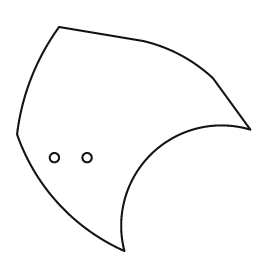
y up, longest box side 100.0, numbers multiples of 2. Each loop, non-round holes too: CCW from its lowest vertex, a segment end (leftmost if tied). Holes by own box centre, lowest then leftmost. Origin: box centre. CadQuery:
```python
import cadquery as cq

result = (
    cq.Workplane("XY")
    .moveTo(-4.0, -48.0)
    .threePointArc((8.0, -6.0), (50.0, 4.0))
    .lineTo(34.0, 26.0)
    .threePointArc((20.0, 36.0), (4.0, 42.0))
    .lineTo(-32.0, 48.0)
    .threePointArc((-44.0, 26.0), (-50.0, 2.0))
    .threePointArc((-32.0, -28.0), (-4.0, -48.0))
    .close()
    .moveTo(-34.0, -8.0)
    .circle(2.0)
    .moveTo(-20.0, -8.0)
    .circle(2.0)
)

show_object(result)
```